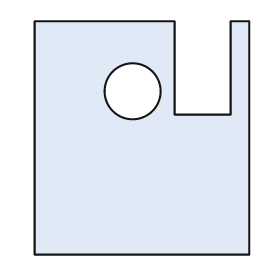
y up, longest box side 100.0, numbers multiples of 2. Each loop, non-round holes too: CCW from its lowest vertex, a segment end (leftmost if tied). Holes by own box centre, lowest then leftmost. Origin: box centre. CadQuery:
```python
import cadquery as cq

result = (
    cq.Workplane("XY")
    .moveTo(-46.0, -50.0)
    .lineTo(46.0, -50.0)
    .lineTo(46.0, 50.0)
    .lineTo(38.0, 50.0)
    .lineTo(38.0, 10.0)
    .lineTo(14.0, 10.0)
    .lineTo(14.0, 50.0)
    .lineTo(-46.0, 50.0)
    .close()
    .moveTo(-4.0, 20.0)
    .circle(12.0)
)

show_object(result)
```